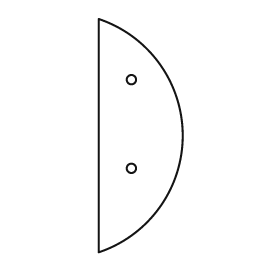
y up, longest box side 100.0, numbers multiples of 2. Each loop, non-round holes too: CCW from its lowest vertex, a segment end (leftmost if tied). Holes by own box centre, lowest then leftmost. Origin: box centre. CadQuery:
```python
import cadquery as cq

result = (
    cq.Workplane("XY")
    .moveTo(-18.0, -50.0)
    .threePointArc((18.0, 0.0), (-18.0, 50.0))
    .close()
    .moveTo(-4.0, -14.0)
    .circle(2.0)
    .moveTo(-4.0, 24.0)
    .circle(2.0)
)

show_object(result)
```